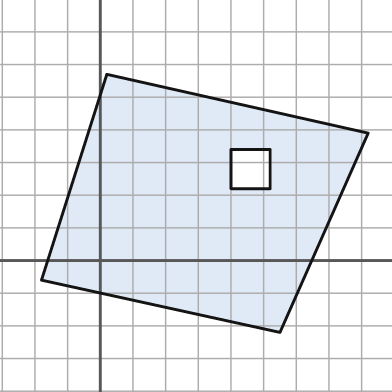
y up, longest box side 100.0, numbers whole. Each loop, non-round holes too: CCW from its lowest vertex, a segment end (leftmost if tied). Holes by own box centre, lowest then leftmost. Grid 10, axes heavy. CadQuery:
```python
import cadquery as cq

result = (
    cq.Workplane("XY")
    .moveTo(55.0, -22.0)
    .lineTo(82.0, 39.0)
    .lineTo(2.0, 57.0)
    .lineTo(-18.0, -6.0)
    .close()
    .moveTo(40.0, 22.0)
    .lineTo(52.0, 22.0)
    .lineTo(52.0, 34.0)
    .lineTo(40.0, 34.0)
    .close()
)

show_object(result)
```